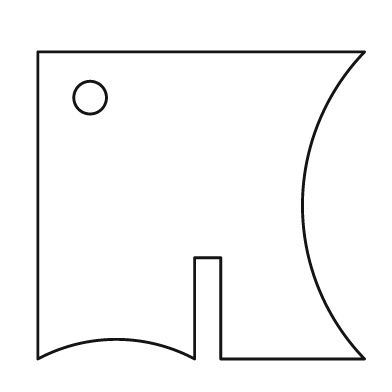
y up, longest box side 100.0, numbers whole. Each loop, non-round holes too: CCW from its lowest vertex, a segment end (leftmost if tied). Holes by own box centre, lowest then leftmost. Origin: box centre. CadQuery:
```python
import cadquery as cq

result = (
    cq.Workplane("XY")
    .moveTo(-50.0, -47.0)
    .threePointArc((-26.0, -41.0), (-2.0, -47.0))
    .lineTo(-2.0, -16.0)
    .lineTo(6.0, -16.0)
    .lineTo(6.0, -47.0)
    .lineTo(50.0, -47.0)
    .threePointArc((31.0, 0.0), (50.0, 47.0))
    .lineTo(-50.0, 47.0)
    .close()
    .moveTo(-34.0, 33.0)
    .circle(5.0)
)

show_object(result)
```